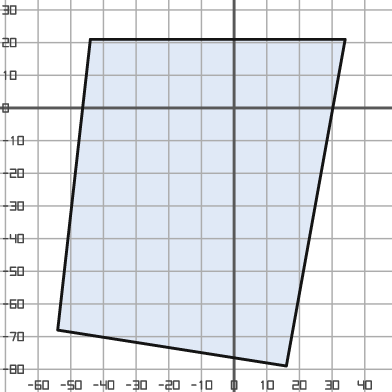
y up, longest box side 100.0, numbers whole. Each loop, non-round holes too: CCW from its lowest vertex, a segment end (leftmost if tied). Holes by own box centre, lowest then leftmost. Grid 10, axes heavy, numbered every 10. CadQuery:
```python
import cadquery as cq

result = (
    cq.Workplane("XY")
    .moveTo(16.0, -79.0)
    .lineTo(34.0, 21.0)
    .lineTo(-44.0, 21.0)
    .lineTo(-54.0, -68.0)
    .close()
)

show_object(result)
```